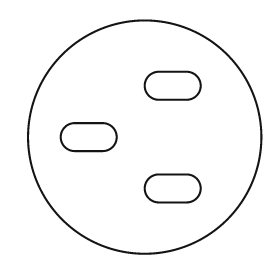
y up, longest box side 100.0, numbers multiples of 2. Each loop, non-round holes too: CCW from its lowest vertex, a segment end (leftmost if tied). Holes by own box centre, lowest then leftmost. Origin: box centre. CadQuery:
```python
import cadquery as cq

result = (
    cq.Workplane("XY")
    .moveTo(0.0, 0.0)
    .circle(50.0)
    .moveTo(6.0, -28.0)
    .lineTo(18.0, -28.0)
    .threePointArc((24.0, -22.0), (18.0, -16.0))
    .lineTo(6.0, -16.0)
    .threePointArc((0.0, -22.0), (6.0, -28.0))
    .close()
    .moveTo(-30.0, -6.0)
    .lineTo(-18.0, -6.0)
    .threePointArc((-12.0, 0.0), (-18.0, 6.0))
    .lineTo(-30.0, 6.0)
    .threePointArc((-36.0, 0.0), (-30.0, -6.0))
    .close()
    .moveTo(6.0, 16.0)
    .lineTo(18.0, 16.0)
    .threePointArc((24.0, 22.0), (18.0, 28.0))
    .lineTo(6.0, 28.0)
    .threePointArc((0.0, 22.0), (6.0, 16.0))
    .close()
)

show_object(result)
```